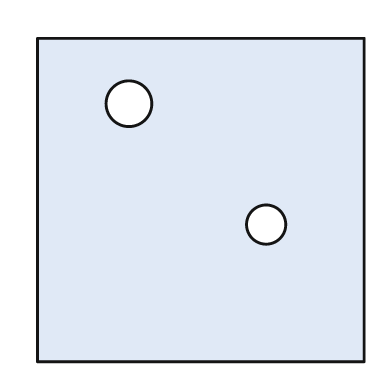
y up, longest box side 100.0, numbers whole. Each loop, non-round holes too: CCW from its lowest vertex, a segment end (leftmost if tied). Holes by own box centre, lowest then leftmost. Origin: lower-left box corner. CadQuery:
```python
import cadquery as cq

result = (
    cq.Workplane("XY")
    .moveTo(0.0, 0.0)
    .lineTo(100.0, 0.0)
    .lineTo(100.0, 99.0)
    .lineTo(0.0, 99.0)
    .close()
    .moveTo(70.0, 42.0)
    .circle(6.0)
    .moveTo(28.0, 79.0)
    .circle(7.0)
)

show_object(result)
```